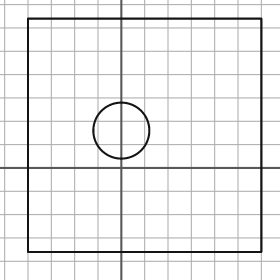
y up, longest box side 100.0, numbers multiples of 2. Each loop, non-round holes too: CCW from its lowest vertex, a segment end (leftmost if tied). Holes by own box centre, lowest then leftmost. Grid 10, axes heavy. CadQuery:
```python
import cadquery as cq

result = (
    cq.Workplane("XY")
    .moveTo(-40.0, -36.0)
    .lineTo(60.0, -36.0)
    .lineTo(60.0, 64.0)
    .lineTo(-40.0, 64.0)
    .close()
    .moveTo(0.0, 16.0)
    .circle(12.0)
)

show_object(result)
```